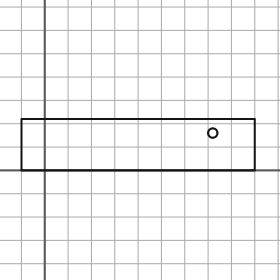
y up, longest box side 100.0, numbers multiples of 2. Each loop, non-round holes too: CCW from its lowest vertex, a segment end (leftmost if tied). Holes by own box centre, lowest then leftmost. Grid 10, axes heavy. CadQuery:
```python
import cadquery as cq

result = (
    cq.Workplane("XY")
    .moveTo(-10.0, 0.0)
    .lineTo(90.0, 0.0)
    .lineTo(90.0, 22.0)
    .lineTo(-10.0, 22.0)
    .close()
    .moveTo(72.0, 16.0)
    .circle(2.0)
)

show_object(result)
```